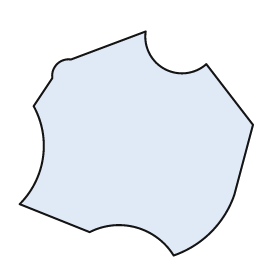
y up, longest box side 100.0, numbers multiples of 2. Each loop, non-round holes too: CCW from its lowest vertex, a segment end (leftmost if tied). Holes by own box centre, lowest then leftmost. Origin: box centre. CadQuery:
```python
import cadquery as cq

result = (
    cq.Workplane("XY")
    .moveTo(16.0, -48.0)
    .threePointArc((32.0, -38.0), (42.0, -22.0))
    .lineTo(50.0, 8.0)
    .lineTo(30.0, 34.0)
    .threePointArc((12.0, 32.0), (4.0, 48.0))
    .lineTo(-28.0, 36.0)
    .threePointArc((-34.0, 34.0), (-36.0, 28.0))
    .lineTo(-44.0, 16.0)
    .threePointArc((-40.0, -6.0), (-50.0, -26.0))
    .lineTo(-20.0, -38.0)
    .threePointArc((0.0, -36.0), (16.0, -48.0))
    .close()
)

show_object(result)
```